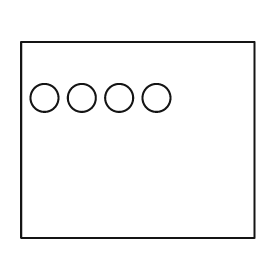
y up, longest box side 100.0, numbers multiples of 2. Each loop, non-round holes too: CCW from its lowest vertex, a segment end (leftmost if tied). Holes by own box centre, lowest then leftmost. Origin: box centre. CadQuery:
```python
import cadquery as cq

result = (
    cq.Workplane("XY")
    .moveTo(-50.0, -42.0)
    .lineTo(50.0, -42.0)
    .lineTo(50.0, 42.0)
    .lineTo(-50.0, 42.0)
    .close()
    .moveTo(-40.0, 18.0)
    .circle(6.0)
    .moveTo(-24.0, 18.0)
    .circle(6.0)
    .moveTo(-8.0, 18.0)
    .circle(6.0)
    .moveTo(8.0, 18.0)
    .circle(6.0)
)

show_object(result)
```